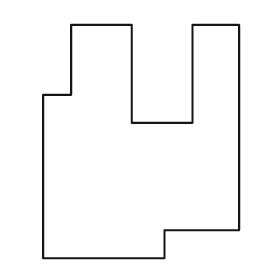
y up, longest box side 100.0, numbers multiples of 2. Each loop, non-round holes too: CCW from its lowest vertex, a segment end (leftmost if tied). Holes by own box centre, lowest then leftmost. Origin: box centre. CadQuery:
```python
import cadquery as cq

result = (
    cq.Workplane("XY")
    .moveTo(-42.0, -50.0)
    .lineTo(10.0, -50.0)
    .lineTo(10.0, -38.0)
    .lineTo(42.0, -38.0)
    .lineTo(42.0, 50.0)
    .lineTo(22.0, 50.0)
    .lineTo(22.0, 8.0)
    .lineTo(-4.0, 8.0)
    .lineTo(-4.0, 50.0)
    .lineTo(-30.0, 50.0)
    .lineTo(-30.0, 20.0)
    .lineTo(-42.0, 20.0)
    .close()
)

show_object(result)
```